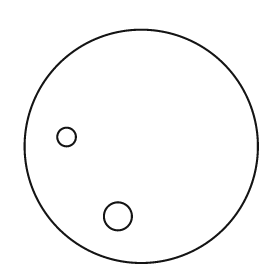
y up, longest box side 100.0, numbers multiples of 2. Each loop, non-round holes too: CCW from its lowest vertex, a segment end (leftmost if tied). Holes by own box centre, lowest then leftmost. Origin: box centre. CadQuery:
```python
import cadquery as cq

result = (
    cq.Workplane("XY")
    .moveTo(0.0, 0.0)
    .circle(50.0)
    .moveTo(-10.0, -30.0)
    .circle(6.0)
    .moveTo(-32.0, 4.0)
    .circle(4.0)
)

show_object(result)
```